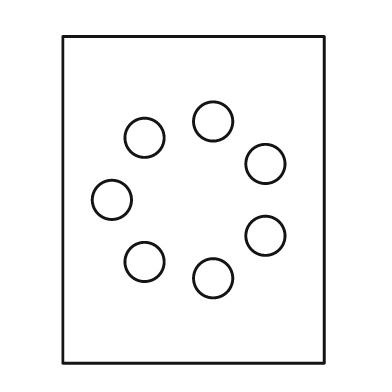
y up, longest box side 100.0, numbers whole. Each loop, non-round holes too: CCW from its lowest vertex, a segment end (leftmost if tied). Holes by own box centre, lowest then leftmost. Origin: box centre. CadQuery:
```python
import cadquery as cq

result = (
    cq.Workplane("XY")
    .moveTo(-40.0, -50.0)
    .lineTo(40.0, -50.0)
    .lineTo(40.0, 50.0)
    .lineTo(-40.0, 50.0)
    .close()
    .moveTo(6.0, -24.0)
    .circle(6.0)
    .moveTo(-15.0, -19.0)
    .circle(6.0)
    .moveTo(22.0, -11.0)
    .circle(6.0)
    .moveTo(-25.0, 0.0)
    .circle(6.0)
    .moveTo(22.0, 11.0)
    .circle(6.0)
    .moveTo(-15.0, 19.0)
    .circle(6.0)
    .moveTo(6.0, 24.0)
    .circle(6.0)
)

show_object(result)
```